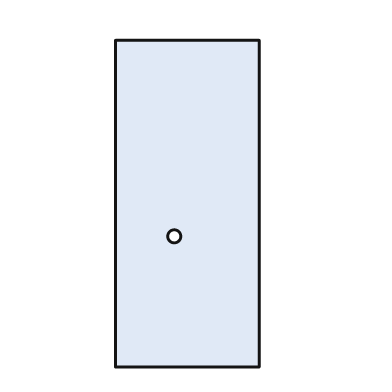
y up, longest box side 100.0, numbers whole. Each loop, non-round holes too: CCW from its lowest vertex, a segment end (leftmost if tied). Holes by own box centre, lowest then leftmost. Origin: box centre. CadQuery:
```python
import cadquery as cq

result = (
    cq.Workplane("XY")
    .moveTo(-22.0, -50.0)
    .lineTo(22.0, -50.0)
    .lineTo(22.0, 50.0)
    .lineTo(-22.0, 50.0)
    .close()
    .moveTo(-4.0, -10.0)
    .circle(2.0)
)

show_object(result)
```